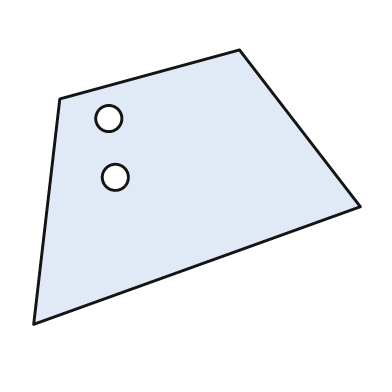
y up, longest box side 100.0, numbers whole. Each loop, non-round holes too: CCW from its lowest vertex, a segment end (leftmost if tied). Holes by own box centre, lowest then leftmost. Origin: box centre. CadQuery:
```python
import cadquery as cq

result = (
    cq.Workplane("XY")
    .moveTo(-50.0, -42.0)
    .lineTo(50.0, -6.0)
    .lineTo(13.0, 42.0)
    .lineTo(-42.0, 27.0)
    .close()
    .moveTo(-25.0, 3.0)
    .circle(4.0)
    .moveTo(-27.0, 21.0)
    .circle(4.0)
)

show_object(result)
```